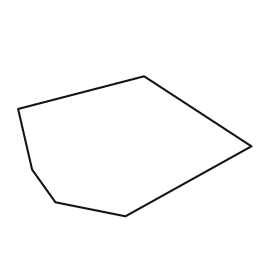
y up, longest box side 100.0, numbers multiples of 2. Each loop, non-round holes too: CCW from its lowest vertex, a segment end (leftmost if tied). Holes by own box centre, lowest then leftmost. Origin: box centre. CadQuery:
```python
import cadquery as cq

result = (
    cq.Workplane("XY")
    .moveTo(-4.0, -30.0)
    .lineTo(50.0, 0.0)
    .lineTo(4.0, 30.0)
    .lineTo(-50.0, 16.0)
    .lineTo(-44.0, -10.0)
    .lineTo(-34.0, -24.0)
    .close()
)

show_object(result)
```